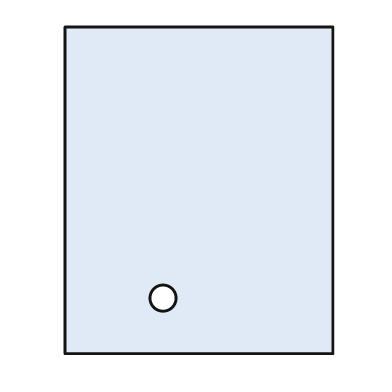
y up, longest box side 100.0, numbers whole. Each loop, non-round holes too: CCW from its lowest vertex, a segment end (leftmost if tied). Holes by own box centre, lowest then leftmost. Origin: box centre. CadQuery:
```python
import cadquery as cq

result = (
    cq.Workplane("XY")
    .moveTo(-41.0, -50.0)
    .lineTo(41.0, -50.0)
    .lineTo(41.0, 50.0)
    .lineTo(-41.0, 50.0)
    .close()
    .moveTo(-11.0, -33.0)
    .circle(4.0)
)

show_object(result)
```